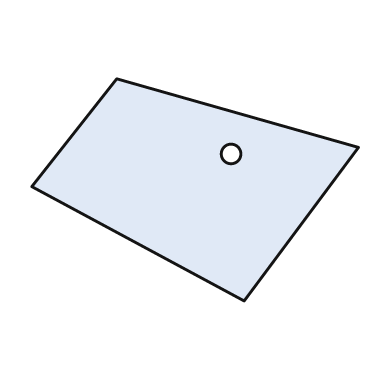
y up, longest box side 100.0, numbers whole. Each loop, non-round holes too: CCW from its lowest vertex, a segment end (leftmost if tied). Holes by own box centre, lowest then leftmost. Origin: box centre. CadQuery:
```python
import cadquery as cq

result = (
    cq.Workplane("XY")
    .moveTo(15.0, -34.0)
    .lineTo(50.0, 13.0)
    .lineTo(-24.0, 34.0)
    .lineTo(-50.0, 1.0)
    .close()
    .moveTo(11.0, 11.0)
    .circle(3.0)
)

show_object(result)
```